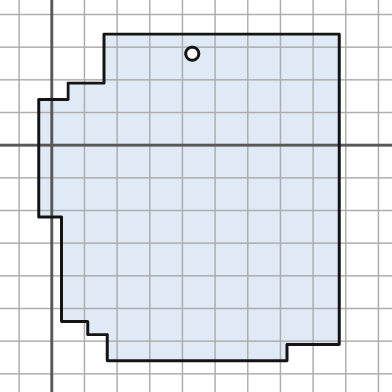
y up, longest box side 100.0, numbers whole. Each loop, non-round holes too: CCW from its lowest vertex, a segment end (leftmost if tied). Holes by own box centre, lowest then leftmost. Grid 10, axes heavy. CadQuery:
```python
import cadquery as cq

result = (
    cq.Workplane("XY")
    .moveTo(17.0, -66.0)
    .lineTo(72.0, -66.0)
    .lineTo(72.0, -61.0)
    .lineTo(88.0, -61.0)
    .lineTo(88.0, 34.0)
    .lineTo(16.0, 34.0)
    .lineTo(16.0, 19.0)
    .lineTo(5.0, 19.0)
    .lineTo(5.0, 14.0)
    .lineTo(-4.0, 14.0)
    .lineTo(-4.0, -22.0)
    .lineTo(3.0, -22.0)
    .lineTo(3.0, -54.0)
    .lineTo(11.0, -54.0)
    .lineTo(11.0, -58.0)
    .lineTo(17.0, -58.0)
    .close()
    .moveTo(43.0, 28.0)
    .circle(2.0)
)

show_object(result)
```